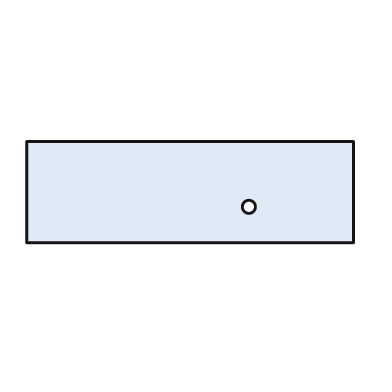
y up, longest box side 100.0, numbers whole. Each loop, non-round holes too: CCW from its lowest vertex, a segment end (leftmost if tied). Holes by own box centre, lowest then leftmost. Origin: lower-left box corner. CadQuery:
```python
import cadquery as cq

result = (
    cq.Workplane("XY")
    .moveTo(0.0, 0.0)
    .lineTo(100.0, 0.0)
    .lineTo(100.0, 31.0)
    .lineTo(0.0, 31.0)
    .close()
    .moveTo(68.0, 11.0)
    .circle(2.0)
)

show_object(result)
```